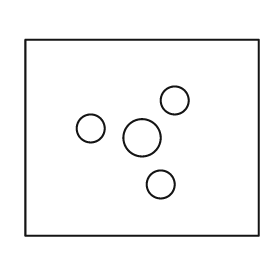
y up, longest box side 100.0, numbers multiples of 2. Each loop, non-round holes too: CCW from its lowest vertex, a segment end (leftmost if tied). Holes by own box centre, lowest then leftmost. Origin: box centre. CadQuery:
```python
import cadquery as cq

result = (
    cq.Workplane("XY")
    .moveTo(-50.0, -42.0)
    .lineTo(50.0, -42.0)
    .lineTo(50.0, 42.0)
    .lineTo(-50.0, 42.0)
    .close()
    .moveTo(8.0, -20.0)
    .circle(6.0)
    .moveTo(0.0, 0.0)
    .circle(8.0)
    .moveTo(-22.0, 4.0)
    .circle(6.0)
    .moveTo(14.0, 16.0)
    .circle(6.0)
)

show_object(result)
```